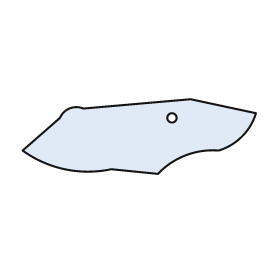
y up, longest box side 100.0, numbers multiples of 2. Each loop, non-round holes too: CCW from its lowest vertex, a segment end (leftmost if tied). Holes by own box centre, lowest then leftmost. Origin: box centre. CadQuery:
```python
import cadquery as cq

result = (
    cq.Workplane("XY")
    .moveTo(8.0, -16.0)
    .threePointArc((20.0, -8.0), (34.0, -6.0))
    .threePointArc((44.0, 0.0), (50.0, 10.0))
    .lineTo(22.0, 16.0)
    .lineTo(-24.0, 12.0)
    .threePointArc((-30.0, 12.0), (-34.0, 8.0))
    .lineTo(-50.0, -6.0)
    .threePointArc((-32.0, -14.0), (-12.0, -14.0))
    .close()
    .moveTo(14.0, 8.0)
    .circle(2.0)
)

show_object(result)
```